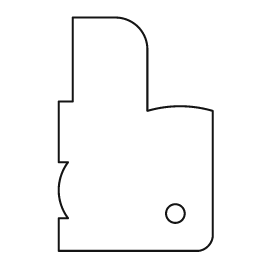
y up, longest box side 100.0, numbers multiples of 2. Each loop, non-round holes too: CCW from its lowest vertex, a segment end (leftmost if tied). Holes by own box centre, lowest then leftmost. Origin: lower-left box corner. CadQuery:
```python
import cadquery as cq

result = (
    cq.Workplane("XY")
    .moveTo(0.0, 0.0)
    .lineTo(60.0, 0.0)
    .threePointArc((64.0, 2.0), (66.0, 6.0))
    .lineTo(66.0, 60.0)
    .threePointArc((52.0, 62.0), (38.0, 60.0))
    .lineTo(38.0, 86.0)
    .threePointArc((34.0, 96.0), (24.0, 100.0))
    .lineTo(6.0, 100.0)
    .lineTo(6.0, 64.0)
    .lineTo(0.0, 64.0)
    .lineTo(0.0, 38.0)
    .lineTo(4.0, 38.0)
    .threePointArc((0.0, 26.0), (4.0, 14.0))
    .lineTo(0.0, 14.0)
    .close()
    .moveTo(50.0, 16.0)
    .circle(4.0)
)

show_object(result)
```